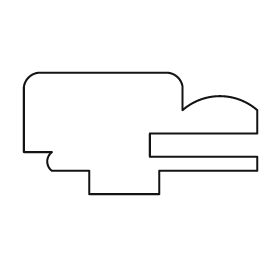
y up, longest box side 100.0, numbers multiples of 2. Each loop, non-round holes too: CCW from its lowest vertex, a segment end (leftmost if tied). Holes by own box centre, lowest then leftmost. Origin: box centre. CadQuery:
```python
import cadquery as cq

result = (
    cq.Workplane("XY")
    .moveTo(-22.0, -26.0)
    .lineTo(8.0, -26.0)
    .lineTo(8.0, -16.0)
    .lineTo(50.0, -16.0)
    .lineTo(50.0, -10.0)
    .lineTo(4.0, -10.0)
    .lineTo(4.0, 0.0)
    .lineTo(50.0, 0.0)
    .lineTo(50.0, 10.0)
    .threePointArc((34.0, 16.0), (18.0, 10.0))
    .lineTo(18.0, 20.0)
    .threePointArc((16.0, 24.0), (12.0, 26.0))
    .lineTo(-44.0, 26.0)
    .threePointArc((-48.0, 24.0), (-50.0, 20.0))
    .lineTo(-50.0, -8.0)
    .lineTo(-38.0, -8.0)
    .threePointArc((-40.0, -12.0), (-38.0, -16.0))
    .lineTo(-22.0, -16.0)
    .close()
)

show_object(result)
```